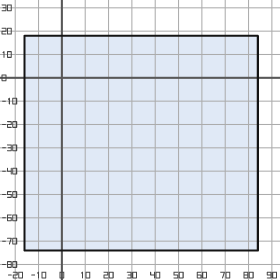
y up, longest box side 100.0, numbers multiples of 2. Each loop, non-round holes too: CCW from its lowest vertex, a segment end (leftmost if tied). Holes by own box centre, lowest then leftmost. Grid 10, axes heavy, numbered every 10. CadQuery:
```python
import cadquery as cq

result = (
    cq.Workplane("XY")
    .moveTo(-16.0, -74.0)
    .lineTo(84.0, -74.0)
    .lineTo(84.0, 18.0)
    .lineTo(-16.0, 18.0)
    .close()
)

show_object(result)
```